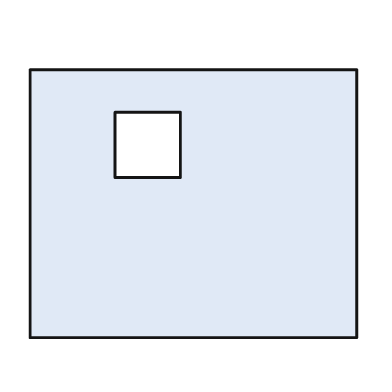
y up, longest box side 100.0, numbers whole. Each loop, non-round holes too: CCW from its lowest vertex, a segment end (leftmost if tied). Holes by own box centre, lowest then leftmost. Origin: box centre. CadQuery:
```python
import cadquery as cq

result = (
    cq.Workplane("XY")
    .moveTo(-50.0, -41.0)
    .lineTo(50.0, -41.0)
    .lineTo(50.0, 41.0)
    .lineTo(-50.0, 41.0)
    .close()
    .moveTo(-24.0, 8.0)
    .lineTo(-4.0, 8.0)
    .lineTo(-4.0, 28.0)
    .lineTo(-24.0, 28.0)
    .close()
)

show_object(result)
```